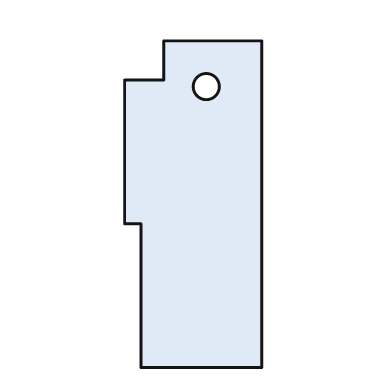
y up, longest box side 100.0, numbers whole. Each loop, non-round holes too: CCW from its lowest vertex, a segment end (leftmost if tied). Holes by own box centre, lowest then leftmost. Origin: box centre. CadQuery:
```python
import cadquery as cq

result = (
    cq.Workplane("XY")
    .moveTo(-16.0, -50.0)
    .lineTo(21.0, -50.0)
    .lineTo(21.0, 50.0)
    .lineTo(-9.0, 50.0)
    .lineTo(-9.0, 38.0)
    .lineTo(-21.0, 38.0)
    .lineTo(-21.0, -6.0)
    .lineTo(-16.0, -6.0)
    .close()
    .moveTo(4.0, 36.0)
    .circle(4.0)
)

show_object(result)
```